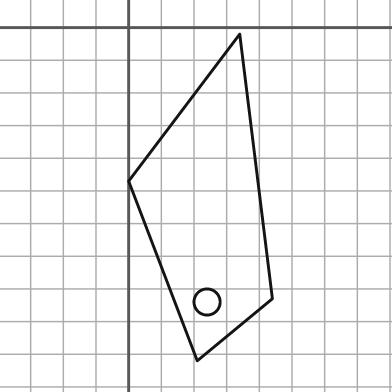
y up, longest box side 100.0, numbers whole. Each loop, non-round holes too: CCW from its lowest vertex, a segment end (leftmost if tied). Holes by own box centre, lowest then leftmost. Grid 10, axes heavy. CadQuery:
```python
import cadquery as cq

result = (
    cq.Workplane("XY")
    .moveTo(21.0, -102.0)
    .lineTo(44.0, -83.0)
    .lineTo(34.0, -2.0)
    .lineTo(0.0, -47.0)
    .close()
    .moveTo(24.0, -84.0)
    .circle(4.0)
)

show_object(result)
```